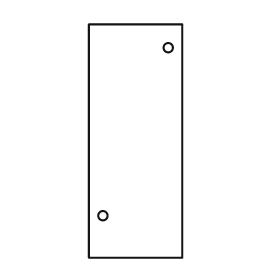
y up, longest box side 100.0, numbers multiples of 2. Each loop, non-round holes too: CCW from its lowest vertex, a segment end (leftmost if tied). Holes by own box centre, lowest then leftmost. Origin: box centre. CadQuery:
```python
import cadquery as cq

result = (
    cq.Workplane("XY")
    .moveTo(-20.0, -50.0)
    .lineTo(20.0, -50.0)
    .lineTo(20.0, 50.0)
    .lineTo(-20.0, 50.0)
    .close()
    .moveTo(-14.0, -32.0)
    .circle(2.0)
    .moveTo(14.0, 40.0)
    .circle(2.0)
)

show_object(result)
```